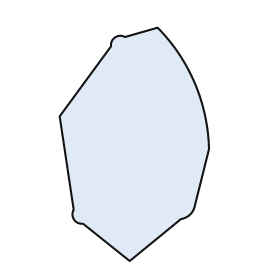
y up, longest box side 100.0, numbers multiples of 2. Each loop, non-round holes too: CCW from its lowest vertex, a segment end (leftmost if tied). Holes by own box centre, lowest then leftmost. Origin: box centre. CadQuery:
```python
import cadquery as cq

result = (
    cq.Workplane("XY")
    .moveTo(-2.0, -50.0)
    .lineTo(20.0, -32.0)
    .threePointArc((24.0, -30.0), (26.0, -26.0))
    .lineTo(32.0, -2.0)
    .threePointArc((26.0, 26.0), (10.0, 50.0))
    .lineTo(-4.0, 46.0)
    .threePointArc((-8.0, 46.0), (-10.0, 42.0))
    .lineTo(-32.0, 12.0)
    .lineTo(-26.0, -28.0)
    .threePointArc((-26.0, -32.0), (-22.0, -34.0))
    .close()
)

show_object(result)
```